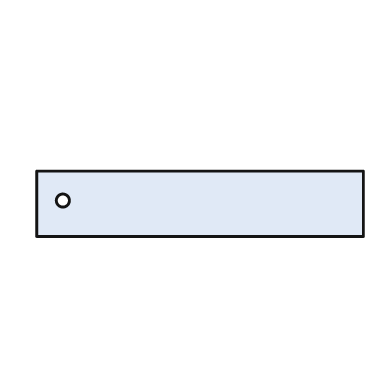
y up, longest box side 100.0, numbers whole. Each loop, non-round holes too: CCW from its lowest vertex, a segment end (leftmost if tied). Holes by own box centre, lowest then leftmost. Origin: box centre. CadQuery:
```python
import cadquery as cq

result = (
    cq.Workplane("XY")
    .moveTo(-50.0, -10.0)
    .lineTo(50.0, -10.0)
    .lineTo(50.0, 10.0)
    .lineTo(-50.0, 10.0)
    .close()
    .moveTo(-42.0, 1.0)
    .circle(2.0)
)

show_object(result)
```